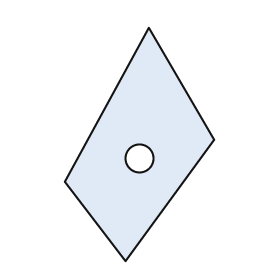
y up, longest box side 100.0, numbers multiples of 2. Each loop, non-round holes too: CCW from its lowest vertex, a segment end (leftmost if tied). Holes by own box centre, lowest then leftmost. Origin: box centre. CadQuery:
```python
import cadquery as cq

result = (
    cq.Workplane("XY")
    .moveTo(-6.0, -50.0)
    .lineTo(32.0, 2.0)
    .lineTo(4.0, 50.0)
    .lineTo(-32.0, -16.0)
    .close()
    .moveTo(0.0, -6.0)
    .circle(6.0)
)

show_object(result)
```